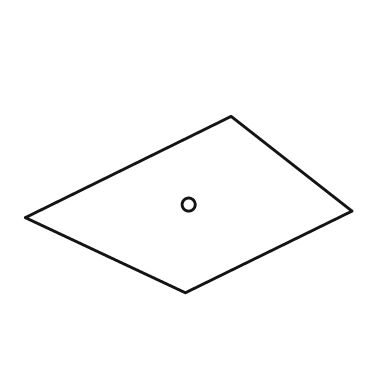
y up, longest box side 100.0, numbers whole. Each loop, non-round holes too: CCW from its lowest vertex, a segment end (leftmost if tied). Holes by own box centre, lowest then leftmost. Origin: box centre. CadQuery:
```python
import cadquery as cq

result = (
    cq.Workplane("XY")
    .moveTo(-1.0, -27.0)
    .lineTo(50.0, -2.0)
    .lineTo(13.0, 27.0)
    .lineTo(-50.0, -4.0)
    .close()
    .moveTo(0.0, 0.0)
    .circle(2.0)
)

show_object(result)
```